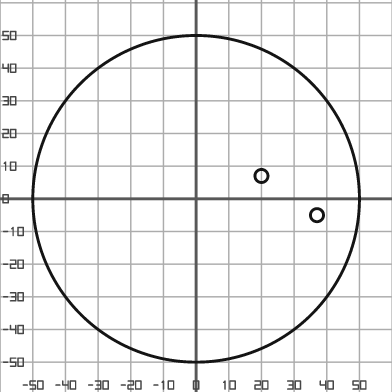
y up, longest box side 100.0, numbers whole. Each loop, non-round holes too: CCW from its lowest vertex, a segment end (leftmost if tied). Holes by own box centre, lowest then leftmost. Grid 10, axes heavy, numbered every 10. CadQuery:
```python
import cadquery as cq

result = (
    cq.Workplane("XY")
    .moveTo(0.0, 0.0)
    .circle(50.0)
    .moveTo(37.0, -5.0)
    .circle(2.0)
    .moveTo(20.0, 7.0)
    .circle(2.0)
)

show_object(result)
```